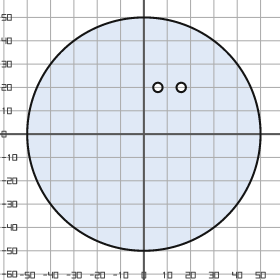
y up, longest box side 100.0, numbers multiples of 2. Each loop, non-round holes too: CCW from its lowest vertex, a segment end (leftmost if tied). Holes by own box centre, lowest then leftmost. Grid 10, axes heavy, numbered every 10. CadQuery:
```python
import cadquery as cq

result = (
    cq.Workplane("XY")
    .moveTo(0.0, 0.0)
    .circle(50.0)
    .moveTo(6.0, 20.0)
    .circle(2.0)
    .moveTo(16.0, 20.0)
    .circle(2.0)
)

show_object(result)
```